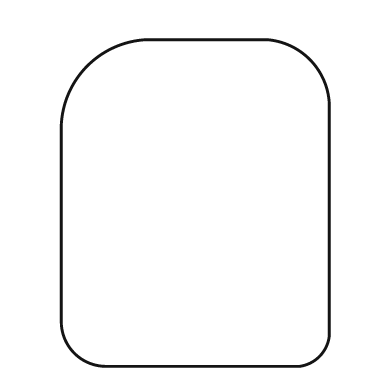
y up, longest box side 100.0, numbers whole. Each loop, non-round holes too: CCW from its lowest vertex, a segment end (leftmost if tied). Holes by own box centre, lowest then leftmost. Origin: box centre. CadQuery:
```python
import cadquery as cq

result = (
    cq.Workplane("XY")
    .moveTo(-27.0, -50.0)
    .lineTo(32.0, -50.0)
    .threePointArc((38.0, -47.0), (41.0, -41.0))
    .lineTo(41.0, 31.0)
    .threePointArc((35.0, 44.0), (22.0, 50.0))
    .lineTo(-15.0, 50.0)
    .threePointArc((-33.0, 42.0), (-41.0, 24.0))
    .lineTo(-41.0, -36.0)
    .threePointArc((-37.0, -46.0), (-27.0, -50.0))
    .close()
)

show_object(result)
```